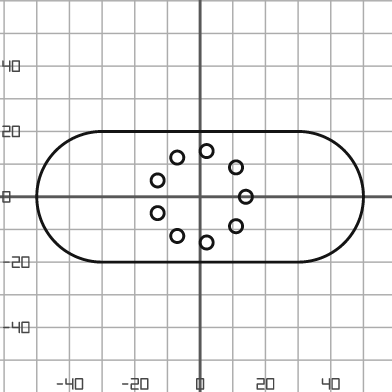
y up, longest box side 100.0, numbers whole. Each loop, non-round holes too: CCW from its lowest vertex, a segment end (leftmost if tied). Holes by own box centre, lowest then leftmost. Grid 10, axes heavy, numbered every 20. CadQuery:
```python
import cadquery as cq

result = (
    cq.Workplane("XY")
    .moveTo(-30.0, -20.0)
    .lineTo(30.0, -20.0)
    .threePointArc((50.0, 0.0), (30.0, 20.0))
    .lineTo(-30.0, 20.0)
    .threePointArc((-50.0, 0.0), (-30.0, -20.0))
    .close()
    .moveTo(2.0, -14.0)
    .circle(2.0)
    .moveTo(-7.0, -12.0)
    .circle(2.0)
    .moveTo(11.0, -9.0)
    .circle(2.0)
    .moveTo(-13.0, -5.0)
    .circle(2.0)
    .moveTo(14.0, 0.0)
    .circle(2.0)
    .moveTo(-13.0, 5.0)
    .circle(2.0)
    .moveTo(11.0, 9.0)
    .circle(2.0)
    .moveTo(-7.0, 12.0)
    .circle(2.0)
    .moveTo(2.0, 14.0)
    .circle(2.0)
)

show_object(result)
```